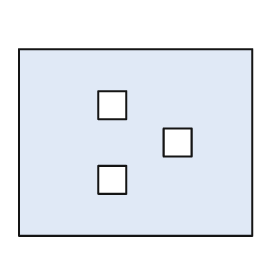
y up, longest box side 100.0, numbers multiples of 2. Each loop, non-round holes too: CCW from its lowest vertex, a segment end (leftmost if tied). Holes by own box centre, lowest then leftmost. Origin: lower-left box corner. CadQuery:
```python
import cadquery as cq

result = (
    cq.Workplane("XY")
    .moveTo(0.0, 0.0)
    .lineTo(100.0, 0.0)
    .lineTo(100.0, 80.0)
    .lineTo(0.0, 80.0)
    .close()
    .moveTo(34.0, 18.0)
    .lineTo(46.0, 18.0)
    .lineTo(46.0, 30.0)
    .lineTo(34.0, 30.0)
    .close()
    .moveTo(62.0, 34.0)
    .lineTo(74.0, 34.0)
    .lineTo(74.0, 46.0)
    .lineTo(62.0, 46.0)
    .close()
    .moveTo(34.0, 50.0)
    .lineTo(46.0, 50.0)
    .lineTo(46.0, 62.0)
    .lineTo(34.0, 62.0)
    .close()
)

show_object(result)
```